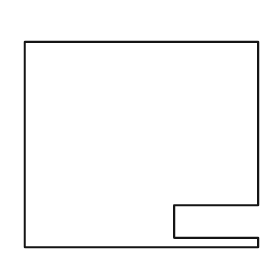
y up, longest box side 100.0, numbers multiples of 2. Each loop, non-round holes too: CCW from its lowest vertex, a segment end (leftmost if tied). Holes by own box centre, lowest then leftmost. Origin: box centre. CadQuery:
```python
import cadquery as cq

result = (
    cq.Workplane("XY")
    .moveTo(-50.0, -44.0)
    .lineTo(50.0, -44.0)
    .lineTo(50.0, -40.0)
    .lineTo(14.0, -40.0)
    .lineTo(14.0, -26.0)
    .lineTo(50.0, -26.0)
    .lineTo(50.0, 44.0)
    .lineTo(-50.0, 44.0)
    .close()
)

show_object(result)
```